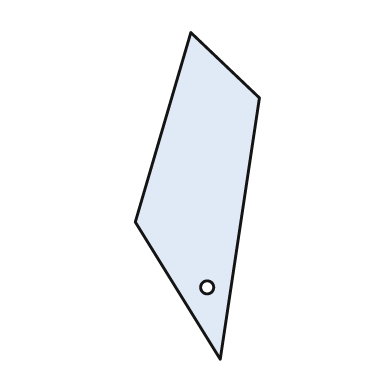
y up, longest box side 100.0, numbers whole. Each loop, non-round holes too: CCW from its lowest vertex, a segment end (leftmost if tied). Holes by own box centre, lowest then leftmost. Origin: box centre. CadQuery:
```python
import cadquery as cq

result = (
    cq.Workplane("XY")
    .moveTo(7.0, -50.0)
    .lineTo(19.0, 30.0)
    .lineTo(-2.0, 50.0)
    .lineTo(-19.0, -8.0)
    .close()
    .moveTo(3.0, -28.0)
    .circle(2.0)
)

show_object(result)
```